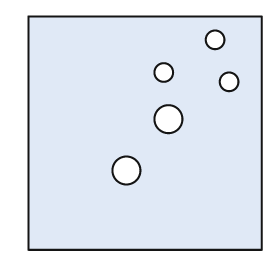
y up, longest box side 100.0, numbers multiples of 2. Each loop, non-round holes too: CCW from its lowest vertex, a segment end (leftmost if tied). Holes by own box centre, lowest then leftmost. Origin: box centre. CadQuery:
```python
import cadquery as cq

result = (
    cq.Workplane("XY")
    .moveTo(-50.0, -50.0)
    .lineTo(50.0, -50.0)
    .lineTo(50.0, 50.0)
    .lineTo(-50.0, 50.0)
    .close()
    .moveTo(-8.0, -16.0)
    .circle(6.0)
    .moveTo(10.0, 6.0)
    .circle(6.0)
    .moveTo(36.0, 22.0)
    .circle(4.0)
    .moveTo(8.0, 26.0)
    .circle(4.0)
    .moveTo(30.0, 40.0)
    .circle(4.0)
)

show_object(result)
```